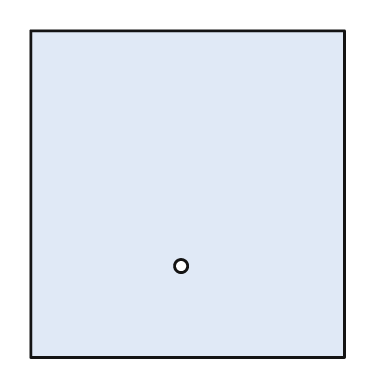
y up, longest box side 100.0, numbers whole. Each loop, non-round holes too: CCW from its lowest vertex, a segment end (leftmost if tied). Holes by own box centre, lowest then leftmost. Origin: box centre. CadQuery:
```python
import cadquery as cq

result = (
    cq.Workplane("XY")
    .moveTo(-48.0, -50.0)
    .lineTo(48.0, -50.0)
    .lineTo(48.0, 50.0)
    .lineTo(-48.0, 50.0)
    .close()
    .moveTo(-2.0, -22.0)
    .circle(2.0)
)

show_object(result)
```